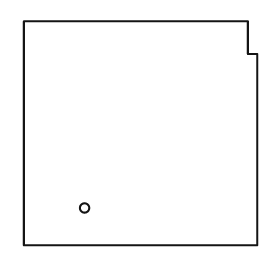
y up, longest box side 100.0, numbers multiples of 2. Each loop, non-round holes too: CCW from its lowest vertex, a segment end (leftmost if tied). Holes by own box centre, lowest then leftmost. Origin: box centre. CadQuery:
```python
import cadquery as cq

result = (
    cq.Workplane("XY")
    .moveTo(-50.0, -48.0)
    .lineTo(50.0, -48.0)
    .lineTo(50.0, 34.0)
    .lineTo(46.0, 34.0)
    .lineTo(46.0, 48.0)
    .lineTo(-50.0, 48.0)
    .close()
    .moveTo(-24.0, -32.0)
    .circle(2.0)
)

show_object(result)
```